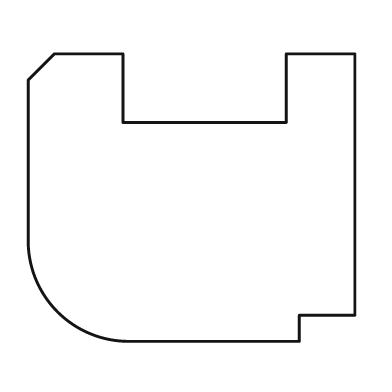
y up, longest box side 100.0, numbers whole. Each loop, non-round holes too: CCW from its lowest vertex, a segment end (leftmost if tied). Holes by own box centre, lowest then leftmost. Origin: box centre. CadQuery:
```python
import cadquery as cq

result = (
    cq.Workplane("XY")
    .moveTo(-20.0, -44.0)
    .lineTo(33.0, -44.0)
    .lineTo(33.0, -36.0)
    .lineTo(50.0, -36.0)
    .lineTo(50.0, 44.0)
    .lineTo(29.0, 44.0)
    .lineTo(29.0, 23.0)
    .lineTo(-21.0, 23.0)
    .lineTo(-21.0, 44.0)
    .lineTo(-42.0, 44.0)
    .lineTo(-50.0, 36.0)
    .lineTo(-50.0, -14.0)
    .threePointArc((-41.0, -35.0), (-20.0, -44.0))
    .close()
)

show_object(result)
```